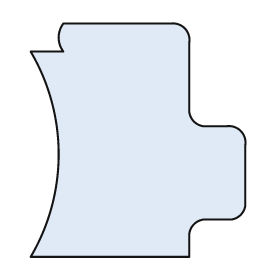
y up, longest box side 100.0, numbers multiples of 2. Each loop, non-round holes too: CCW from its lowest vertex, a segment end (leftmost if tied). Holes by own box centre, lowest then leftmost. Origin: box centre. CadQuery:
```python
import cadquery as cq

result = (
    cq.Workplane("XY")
    .moveTo(-46.0, -50.0)
    .lineTo(22.0, -50.0)
    .lineTo(22.0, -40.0)
    .threePointArc((24.0, -36.0), (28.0, -34.0))
    .lineTo(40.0, -34.0)
    .threePointArc((44.0, -32.0), (46.0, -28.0))
    .lineTo(46.0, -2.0)
    .threePointArc((44.0, 4.0), (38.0, 6.0))
    .lineTo(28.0, 6.0)
    .threePointArc((24.0, 8.0), (22.0, 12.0))
    .lineTo(22.0, 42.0)
    .threePointArc((20.0, 48.0), (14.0, 50.0))
    .lineTo(-32.0, 50.0)
    .threePointArc((-34.0, 44.0), (-32.0, 38.0))
    .lineTo(-46.0, 38.0)
    .threePointArc((-34.0, -6.0), (-46.0, -50.0))
    .close()
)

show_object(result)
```